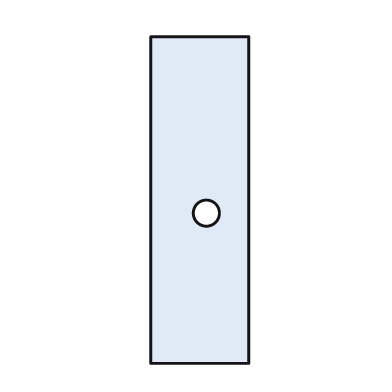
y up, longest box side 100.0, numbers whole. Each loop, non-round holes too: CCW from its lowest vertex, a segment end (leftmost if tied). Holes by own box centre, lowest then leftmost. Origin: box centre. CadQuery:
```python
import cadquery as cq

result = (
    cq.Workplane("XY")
    .moveTo(-15.0, -50.0)
    .lineTo(15.0, -50.0)
    .lineTo(15.0, 50.0)
    .lineTo(-15.0, 50.0)
    .close()
    .moveTo(2.0, -4.0)
    .circle(4.0)
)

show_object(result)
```